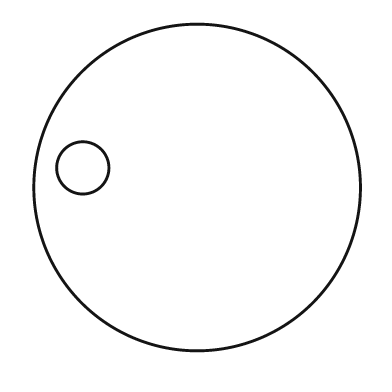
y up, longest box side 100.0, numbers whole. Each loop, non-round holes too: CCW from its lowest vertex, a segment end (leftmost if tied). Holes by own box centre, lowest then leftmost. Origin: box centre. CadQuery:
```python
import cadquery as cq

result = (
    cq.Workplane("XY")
    .moveTo(0.0, 0.0)
    .circle(50.0)
    .moveTo(-35.0, 6.0)
    .circle(8.0)
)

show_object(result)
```